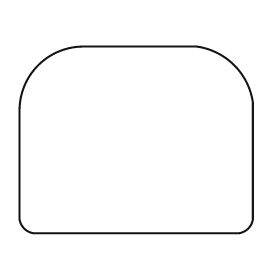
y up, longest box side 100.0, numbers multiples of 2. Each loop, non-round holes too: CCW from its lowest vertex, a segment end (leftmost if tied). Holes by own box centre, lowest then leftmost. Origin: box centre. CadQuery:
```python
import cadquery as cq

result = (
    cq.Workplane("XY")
    .moveTo(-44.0, -40.0)
    .lineTo(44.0, -40.0)
    .threePointArc((48.0, -38.0), (50.0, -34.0))
    .lineTo(50.0, 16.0)
    .threePointArc((42.0, 32.0), (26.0, 40.0))
    .lineTo(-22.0, 40.0)
    .threePointArc((-42.0, 32.0), (-50.0, 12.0))
    .lineTo(-50.0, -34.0)
    .threePointArc((-48.0, -38.0), (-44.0, -40.0))
    .close()
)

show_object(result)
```